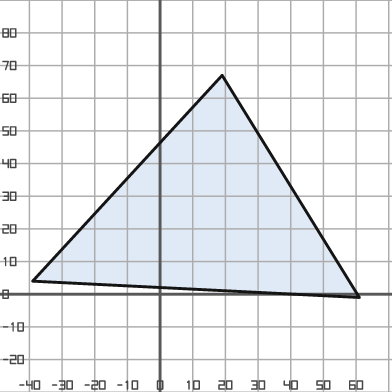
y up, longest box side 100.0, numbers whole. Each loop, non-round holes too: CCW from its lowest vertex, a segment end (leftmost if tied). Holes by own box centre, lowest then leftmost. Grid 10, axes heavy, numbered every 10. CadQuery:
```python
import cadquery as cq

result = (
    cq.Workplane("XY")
    .moveTo(61.0, -1.0)
    .lineTo(19.0, 67.0)
    .lineTo(-39.0, 4.0)
    .close()
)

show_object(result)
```